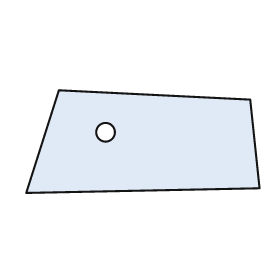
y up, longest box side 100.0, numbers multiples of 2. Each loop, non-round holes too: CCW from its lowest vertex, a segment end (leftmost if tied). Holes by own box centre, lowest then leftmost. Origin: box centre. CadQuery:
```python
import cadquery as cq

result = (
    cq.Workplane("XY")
    .moveTo(-50.0, -22.0)
    .lineTo(50.0, -20.0)
    .lineTo(46.0, 18.0)
    .lineTo(-36.0, 22.0)
    .close()
    .moveTo(-16.0, 4.0)
    .circle(4.0)
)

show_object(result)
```